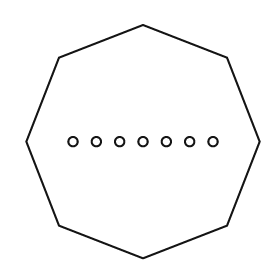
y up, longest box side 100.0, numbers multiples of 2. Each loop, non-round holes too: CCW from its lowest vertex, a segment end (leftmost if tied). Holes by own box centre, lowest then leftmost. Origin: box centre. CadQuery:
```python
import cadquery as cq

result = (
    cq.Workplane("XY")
    .moveTo(0.0, -50.0)
    .lineTo(36.0, -36.0)
    .lineTo(50.0, 0.0)
    .lineTo(36.0, 36.0)
    .lineTo(0.0, 50.0)
    .lineTo(-36.0, 36.0)
    .lineTo(-50.0, 0.0)
    .lineTo(-36.0, -36.0)
    .close()
    .moveTo(-30.0, 0.0)
    .circle(2.0)
    .moveTo(-20.0, 0.0)
    .circle(2.0)
    .moveTo(-10.0, 0.0)
    .circle(2.0)
    .moveTo(0.0, 0.0)
    .circle(2.0)
    .moveTo(10.0, 0.0)
    .circle(2.0)
    .moveTo(20.0, 0.0)
    .circle(2.0)
    .moveTo(30.0, 0.0)
    .circle(2.0)
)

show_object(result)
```